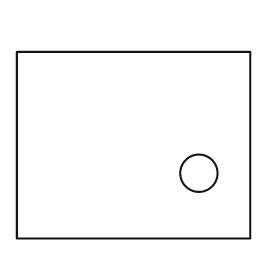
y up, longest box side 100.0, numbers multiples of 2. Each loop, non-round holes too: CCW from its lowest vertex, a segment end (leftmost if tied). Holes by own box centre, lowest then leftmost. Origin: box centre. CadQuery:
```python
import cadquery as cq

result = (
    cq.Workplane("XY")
    .moveTo(-50.0, -40.0)
    .lineTo(50.0, -40.0)
    .lineTo(50.0, 40.0)
    .lineTo(-50.0, 40.0)
    .close()
    .moveTo(28.0, -12.0)
    .circle(8.0)
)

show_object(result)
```